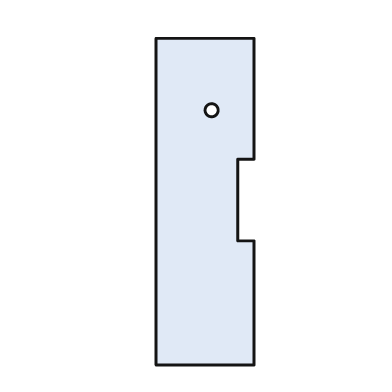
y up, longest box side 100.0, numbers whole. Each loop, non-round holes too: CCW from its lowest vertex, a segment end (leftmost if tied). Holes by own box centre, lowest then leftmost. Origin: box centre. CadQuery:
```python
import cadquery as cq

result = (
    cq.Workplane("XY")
    .moveTo(-15.0, -50.0)
    .lineTo(15.0, -50.0)
    .lineTo(15.0, -12.0)
    .lineTo(10.0, -12.0)
    .lineTo(10.0, 13.0)
    .lineTo(15.0, 13.0)
    .lineTo(15.0, 50.0)
    .lineTo(-15.0, 50.0)
    .close()
    .moveTo(2.0, 28.0)
    .circle(2.0)
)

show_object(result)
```